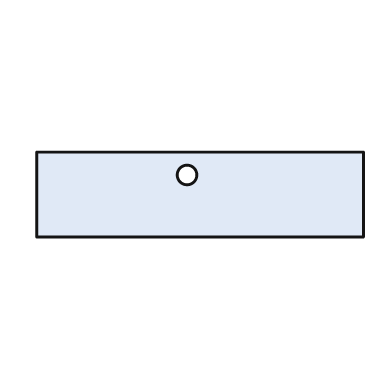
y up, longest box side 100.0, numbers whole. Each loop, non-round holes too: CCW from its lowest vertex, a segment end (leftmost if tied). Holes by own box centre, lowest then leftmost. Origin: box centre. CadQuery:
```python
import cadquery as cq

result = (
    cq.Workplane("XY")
    .moveTo(-50.0, -13.0)
    .lineTo(50.0, -13.0)
    .lineTo(50.0, 13.0)
    .lineTo(-50.0, 13.0)
    .close()
    .moveTo(-4.0, 6.0)
    .circle(3.0)
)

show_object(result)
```